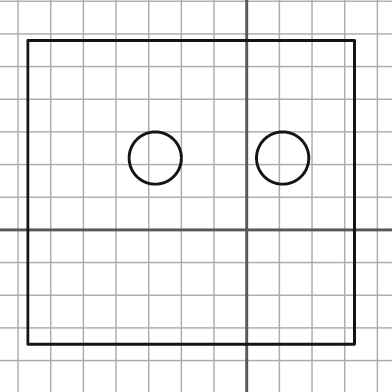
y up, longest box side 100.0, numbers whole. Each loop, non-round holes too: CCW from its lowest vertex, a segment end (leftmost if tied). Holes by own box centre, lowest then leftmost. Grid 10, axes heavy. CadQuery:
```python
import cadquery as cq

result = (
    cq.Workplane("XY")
    .moveTo(-67.0, -35.0)
    .lineTo(33.0, -35.0)
    .lineTo(33.0, 58.0)
    .lineTo(-67.0, 58.0)
    .close()
    .moveTo(-28.0, 22.0)
    .circle(8.0)
    .moveTo(11.0, 22.0)
    .circle(8.0)
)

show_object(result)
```